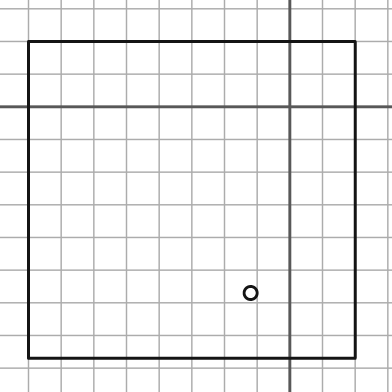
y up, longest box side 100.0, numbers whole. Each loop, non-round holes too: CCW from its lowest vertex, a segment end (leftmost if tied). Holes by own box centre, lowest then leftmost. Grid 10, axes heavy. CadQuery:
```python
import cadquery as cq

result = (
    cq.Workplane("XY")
    .moveTo(-80.0, -77.0)
    .lineTo(20.0, -77.0)
    .lineTo(20.0, 20.0)
    .lineTo(-80.0, 20.0)
    .close()
    .moveTo(-12.0, -57.0)
    .circle(2.0)
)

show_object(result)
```